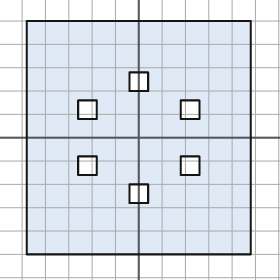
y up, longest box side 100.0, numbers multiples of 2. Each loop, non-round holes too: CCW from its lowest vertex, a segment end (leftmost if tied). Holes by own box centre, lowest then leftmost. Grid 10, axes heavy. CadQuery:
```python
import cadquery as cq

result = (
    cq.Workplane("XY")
    .moveTo(-48.0, -50.0)
    .lineTo(48.0, -50.0)
    .lineTo(48.0, 50.0)
    .lineTo(-48.0, 50.0)
    .close()
    .moveTo(-4.0, -28.0)
    .lineTo(4.0, -28.0)
    .lineTo(4.0, -20.0)
    .lineTo(-4.0, -20.0)
    .close()
    .moveTo(-26.0, -16.0)
    .lineTo(-18.0, -16.0)
    .lineTo(-18.0, -8.0)
    .lineTo(-26.0, -8.0)
    .close()
    .moveTo(18.0, -16.0)
    .lineTo(26.0, -16.0)
    .lineTo(26.0, -8.0)
    .lineTo(18.0, -8.0)
    .close()
    .moveTo(-26.0, 8.0)
    .lineTo(-18.0, 8.0)
    .lineTo(-18.0, 16.0)
    .lineTo(-26.0, 16.0)
    .close()
    .moveTo(18.0, 8.0)
    .lineTo(26.0, 8.0)
    .lineTo(26.0, 16.0)
    .lineTo(18.0, 16.0)
    .close()
    .moveTo(-4.0, 20.0)
    .lineTo(4.0, 20.0)
    .lineTo(4.0, 28.0)
    .lineTo(-4.0, 28.0)
    .close()
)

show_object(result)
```